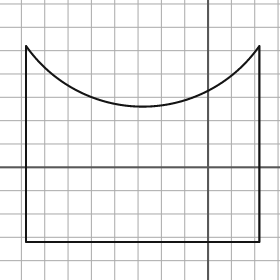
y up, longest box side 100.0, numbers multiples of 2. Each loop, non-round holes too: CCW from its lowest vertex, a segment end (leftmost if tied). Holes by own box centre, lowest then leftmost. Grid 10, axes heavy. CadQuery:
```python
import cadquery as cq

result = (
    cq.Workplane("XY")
    .moveTo(-78.0, -32.0)
    .lineTo(22.0, -32.0)
    .lineTo(22.0, 52.0)
    .threePointArc((-28.0, 26.0), (-78.0, 52.0))
    .close()
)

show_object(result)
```